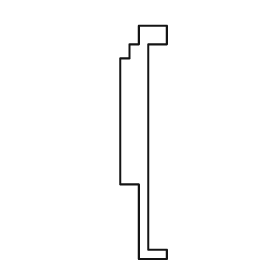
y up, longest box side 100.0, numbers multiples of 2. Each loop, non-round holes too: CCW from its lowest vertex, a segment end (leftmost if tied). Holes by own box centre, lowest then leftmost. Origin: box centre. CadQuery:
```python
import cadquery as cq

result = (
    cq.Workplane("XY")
    .moveTo(-2.0, -50.0)
    .lineTo(10.0, -50.0)
    .lineTo(10.0, -46.0)
    .lineTo(2.0, -46.0)
    .lineTo(2.0, 42.0)
    .lineTo(10.0, 42.0)
    .lineTo(10.0, 50.0)
    .lineTo(-2.0, 50.0)
    .lineTo(-2.0, 42.0)
    .lineTo(-6.0, 42.0)
    .lineTo(-6.0, 36.0)
    .lineTo(-10.0, 36.0)
    .lineTo(-10.0, -18.0)
    .lineTo(-2.0, -18.0)
    .close()
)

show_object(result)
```